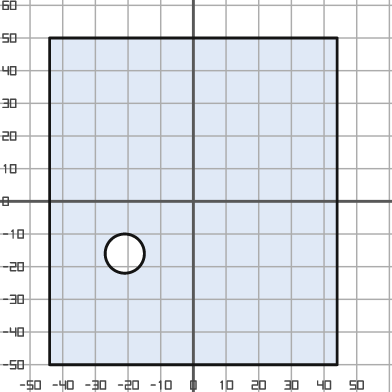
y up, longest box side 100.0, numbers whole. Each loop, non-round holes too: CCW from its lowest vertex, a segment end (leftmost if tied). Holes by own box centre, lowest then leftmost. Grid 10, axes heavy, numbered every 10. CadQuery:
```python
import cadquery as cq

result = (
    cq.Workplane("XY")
    .moveTo(-44.0, -50.0)
    .lineTo(44.0, -50.0)
    .lineTo(44.0, 50.0)
    .lineTo(-44.0, 50.0)
    .close()
    .moveTo(-21.0, -16.0)
    .circle(6.0)
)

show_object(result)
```